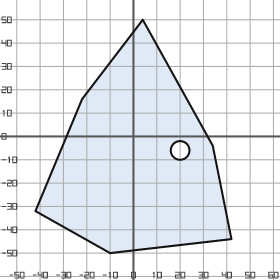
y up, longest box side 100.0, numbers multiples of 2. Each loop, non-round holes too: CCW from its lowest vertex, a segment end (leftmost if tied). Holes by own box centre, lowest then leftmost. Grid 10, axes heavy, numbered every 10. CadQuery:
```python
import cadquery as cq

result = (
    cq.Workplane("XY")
    .moveTo(-10.0, -50.0)
    .lineTo(42.0, -44.0)
    .lineTo(34.0, -4.0)
    .lineTo(4.0, 50.0)
    .lineTo(-22.0, 16.0)
    .lineTo(-42.0, -32.0)
    .close()
    .moveTo(20.0, -6.0)
    .circle(4.0)
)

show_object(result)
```